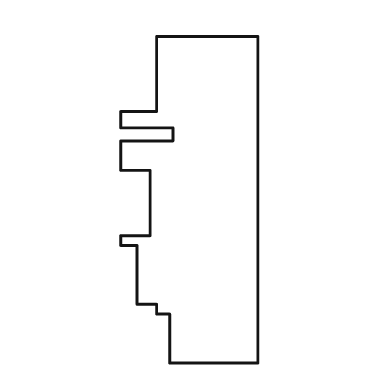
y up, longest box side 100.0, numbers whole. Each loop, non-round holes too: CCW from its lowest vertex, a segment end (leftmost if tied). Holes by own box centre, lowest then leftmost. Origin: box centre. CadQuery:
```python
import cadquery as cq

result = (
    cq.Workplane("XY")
    .moveTo(-6.0, -50.0)
    .lineTo(21.0, -50.0)
    .lineTo(21.0, 50.0)
    .lineTo(-10.0, 50.0)
    .lineTo(-10.0, 27.0)
    .lineTo(-21.0, 27.0)
    .lineTo(-21.0, 22.0)
    .lineTo(-5.0, 22.0)
    .lineTo(-5.0, 18.0)
    .lineTo(-21.0, 18.0)
    .lineTo(-21.0, 9.0)
    .lineTo(-12.0, 9.0)
    .lineTo(-12.0, -11.0)
    .lineTo(-21.0, -11.0)
    .lineTo(-21.0, -14.0)
    .lineTo(-16.0, -14.0)
    .lineTo(-16.0, -32.0)
    .lineTo(-10.0, -32.0)
    .lineTo(-10.0, -35.0)
    .lineTo(-6.0, -35.0)
    .close()
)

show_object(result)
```